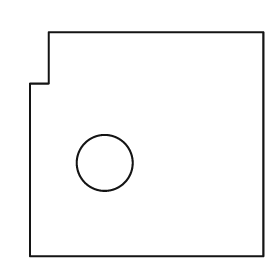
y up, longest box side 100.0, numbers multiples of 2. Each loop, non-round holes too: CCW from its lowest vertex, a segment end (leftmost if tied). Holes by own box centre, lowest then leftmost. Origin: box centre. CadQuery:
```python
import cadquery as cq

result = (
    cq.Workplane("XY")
    .moveTo(-50.0, -48.0)
    .lineTo(50.0, -48.0)
    .lineTo(50.0, 48.0)
    .lineTo(-42.0, 48.0)
    .lineTo(-42.0, 26.0)
    .lineTo(-50.0, 26.0)
    .close()
    .moveTo(-18.0, -8.0)
    .circle(12.0)
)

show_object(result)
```